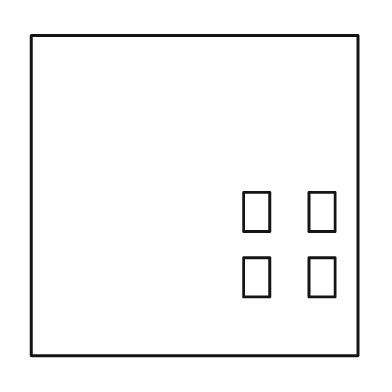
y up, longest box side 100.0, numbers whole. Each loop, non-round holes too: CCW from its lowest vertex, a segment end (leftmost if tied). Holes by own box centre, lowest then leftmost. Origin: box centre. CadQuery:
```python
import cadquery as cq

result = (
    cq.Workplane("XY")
    .moveTo(-50.0, -49.0)
    .lineTo(50.0, -49.0)
    .lineTo(50.0, 49.0)
    .lineTo(-50.0, 49.0)
    .close()
    .moveTo(15.0, -31.0)
    .lineTo(23.0, -31.0)
    .lineTo(23.0, -19.0)
    .lineTo(15.0, -19.0)
    .close()
    .moveTo(35.0, -31.0)
    .lineTo(43.0, -31.0)
    .lineTo(43.0, -19.0)
    .lineTo(35.0, -19.0)
    .close()
    .moveTo(15.0, -11.0)
    .lineTo(23.0, -11.0)
    .lineTo(23.0, 1.0)
    .lineTo(15.0, 1.0)
    .close()
    .moveTo(35.0, -11.0)
    .lineTo(43.0, -11.0)
    .lineTo(43.0, 1.0)
    .lineTo(35.0, 1.0)
    .close()
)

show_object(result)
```